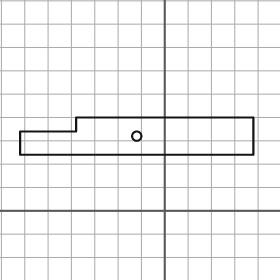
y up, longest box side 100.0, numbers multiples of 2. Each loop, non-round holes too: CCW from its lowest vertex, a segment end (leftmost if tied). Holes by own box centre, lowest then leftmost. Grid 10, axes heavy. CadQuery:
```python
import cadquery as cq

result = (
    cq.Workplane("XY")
    .moveTo(-62.0, 24.0)
    .lineTo(38.0, 24.0)
    .lineTo(38.0, 40.0)
    .lineTo(-38.0, 40.0)
    .lineTo(-38.0, 34.0)
    .lineTo(-62.0, 34.0)
    .close()
    .moveTo(-12.0, 32.0)
    .circle(2.0)
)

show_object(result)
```